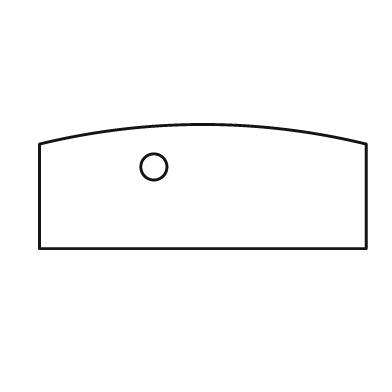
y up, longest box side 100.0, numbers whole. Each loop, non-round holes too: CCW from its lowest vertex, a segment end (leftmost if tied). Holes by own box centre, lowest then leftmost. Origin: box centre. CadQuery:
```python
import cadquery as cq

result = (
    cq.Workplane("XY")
    .moveTo(-50.0, -19.0)
    .lineTo(50.0, -19.0)
    .lineTo(50.0, 13.0)
    .threePointArc((0.0, 19.0), (-50.0, 13.0))
    .close()
    .moveTo(-15.0, 6.0)
    .circle(4.0)
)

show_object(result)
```